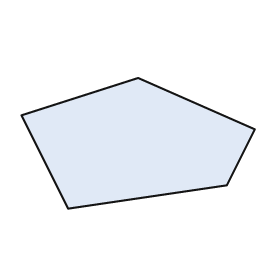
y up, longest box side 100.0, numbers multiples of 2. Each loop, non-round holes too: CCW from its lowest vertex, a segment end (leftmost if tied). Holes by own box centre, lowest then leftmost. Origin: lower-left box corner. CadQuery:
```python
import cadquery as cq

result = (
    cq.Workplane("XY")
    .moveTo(20.0, 0.0)
    .lineTo(88.0, 10.0)
    .lineTo(100.0, 34.0)
    .lineTo(50.0, 56.0)
    .lineTo(0.0, 40.0)
    .close()
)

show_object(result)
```